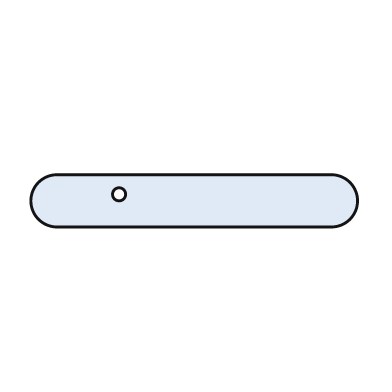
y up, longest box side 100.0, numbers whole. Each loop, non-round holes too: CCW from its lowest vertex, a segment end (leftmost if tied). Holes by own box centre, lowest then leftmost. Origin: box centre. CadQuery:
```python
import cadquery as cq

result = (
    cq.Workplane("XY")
    .moveTo(-42.0, -8.0)
    .lineTo(42.0, -8.0)
    .threePointArc((50.0, 0.0), (42.0, 8.0))
    .lineTo(-42.0, 8.0)
    .threePointArc((-50.0, 0.0), (-42.0, -8.0))
    .close()
    .moveTo(-23.0, 2.0)
    .circle(2.0)
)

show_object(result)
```